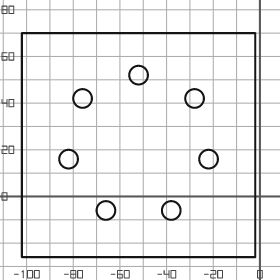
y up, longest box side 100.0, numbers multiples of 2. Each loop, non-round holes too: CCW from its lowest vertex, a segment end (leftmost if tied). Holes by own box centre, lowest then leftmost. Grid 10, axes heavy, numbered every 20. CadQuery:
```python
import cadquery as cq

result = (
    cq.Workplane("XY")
    .moveTo(-102.0, -26.0)
    .lineTo(-2.0, -26.0)
    .lineTo(-2.0, 70.0)
    .lineTo(-102.0, 70.0)
    .close()
    .moveTo(-66.0, -6.0)
    .circle(4.0)
    .moveTo(-38.0, -6.0)
    .circle(4.0)
    .moveTo(-82.0, 16.0)
    .circle(4.0)
    .moveTo(-22.0, 16.0)
    .circle(4.0)
    .moveTo(-76.0, 42.0)
    .circle(4.0)
    .moveTo(-28.0, 42.0)
    .circle(4.0)
    .moveTo(-52.0, 52.0)
    .circle(4.0)
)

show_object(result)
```